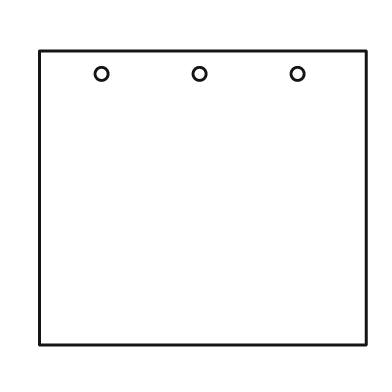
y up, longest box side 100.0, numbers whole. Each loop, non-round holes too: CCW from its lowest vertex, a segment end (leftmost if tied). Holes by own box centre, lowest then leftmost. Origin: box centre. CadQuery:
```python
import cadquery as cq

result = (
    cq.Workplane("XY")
    .moveTo(-50.0, -45.0)
    .lineTo(50.0, -45.0)
    .lineTo(50.0, 45.0)
    .lineTo(-50.0, 45.0)
    .close()
    .moveTo(-31.0, 38.0)
    .circle(2.0)
    .moveTo(-1.0, 38.0)
    .circle(2.0)
    .moveTo(29.0, 38.0)
    .circle(2.0)
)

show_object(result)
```